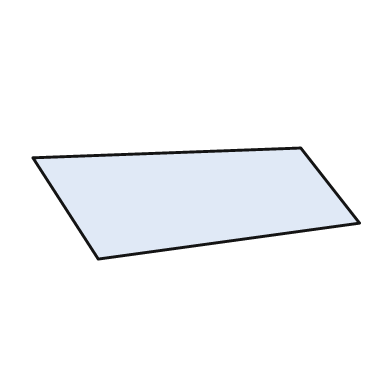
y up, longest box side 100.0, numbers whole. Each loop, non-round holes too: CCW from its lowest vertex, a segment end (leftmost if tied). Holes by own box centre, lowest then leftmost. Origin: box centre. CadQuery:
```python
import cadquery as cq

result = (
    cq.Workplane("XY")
    .moveTo(-30.0, -17.0)
    .lineTo(50.0, -6.0)
    .lineTo(32.0, 17.0)
    .lineTo(-50.0, 14.0)
    .close()
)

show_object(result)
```